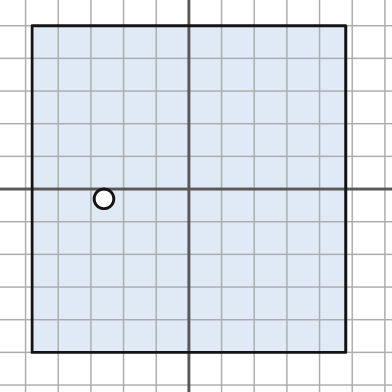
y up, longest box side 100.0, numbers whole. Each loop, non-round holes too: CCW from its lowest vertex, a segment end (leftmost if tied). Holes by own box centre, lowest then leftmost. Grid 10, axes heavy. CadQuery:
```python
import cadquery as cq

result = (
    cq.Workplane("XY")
    .moveTo(-48.0, -50.0)
    .lineTo(48.0, -50.0)
    .lineTo(48.0, 50.0)
    .lineTo(-48.0, 50.0)
    .close()
    .moveTo(-26.0, -3.0)
    .circle(3.0)
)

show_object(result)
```